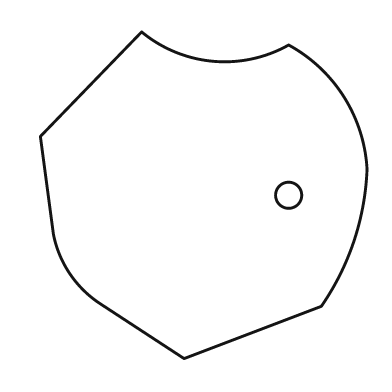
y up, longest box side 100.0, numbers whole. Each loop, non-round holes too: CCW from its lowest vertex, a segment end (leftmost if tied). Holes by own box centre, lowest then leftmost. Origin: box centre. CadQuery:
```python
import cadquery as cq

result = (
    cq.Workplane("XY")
    .moveTo(-6.0, -50.0)
    .lineTo(36.0, -34.0)
    .threePointArc((46.0, -14.0), (50.0, 8.0))
    .threePointArc((43.0, 30.0), (26.0, 46.0))
    .threePointArc((3.0, 41.0), (-19.0, 50.0))
    .lineTo(-50.0, 18.0)
    .lineTo(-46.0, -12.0)
    .threePointArc((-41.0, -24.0), (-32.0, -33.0))
    .close()
    .moveTo(26.0, 0.0)
    .circle(4.0)
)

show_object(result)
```